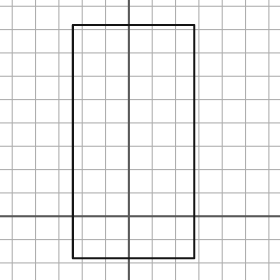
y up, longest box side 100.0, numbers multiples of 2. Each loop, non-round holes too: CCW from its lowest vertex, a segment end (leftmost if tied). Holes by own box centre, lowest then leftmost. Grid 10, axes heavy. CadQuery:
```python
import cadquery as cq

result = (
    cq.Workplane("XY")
    .moveTo(-24.0, -18.0)
    .lineTo(28.0, -18.0)
    .lineTo(28.0, 82.0)
    .lineTo(-24.0, 82.0)
    .close()
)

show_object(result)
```